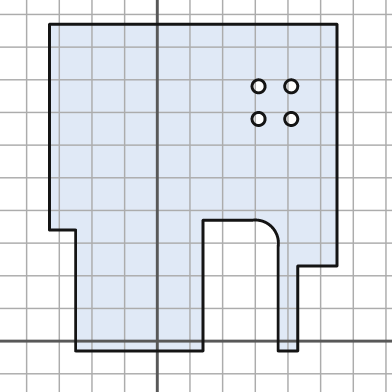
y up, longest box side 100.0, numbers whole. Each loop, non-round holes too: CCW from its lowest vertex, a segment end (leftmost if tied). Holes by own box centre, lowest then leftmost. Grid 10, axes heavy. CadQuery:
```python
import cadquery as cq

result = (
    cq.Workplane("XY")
    .moveTo(-25.0, -3.0)
    .lineTo(14.0, -3.0)
    .lineTo(14.0, 37.0)
    .lineTo(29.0, 37.0)
    .threePointArc((35.0, 35.0), (37.0, 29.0))
    .lineTo(37.0, -3.0)
    .lineTo(43.0, -3.0)
    .lineTo(43.0, 23.0)
    .lineTo(55.0, 23.0)
    .lineTo(55.0, 97.0)
    .lineTo(-33.0, 97.0)
    .lineTo(-33.0, 34.0)
    .lineTo(-25.0, 34.0)
    .close()
    .moveTo(31.0, 68.0)
    .circle(2.0)
    .moveTo(41.0, 68.0)
    .circle(2.0)
    .moveTo(31.0, 78.0)
    .circle(2.0)
    .moveTo(41.0, 78.0)
    .circle(2.0)
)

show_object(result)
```